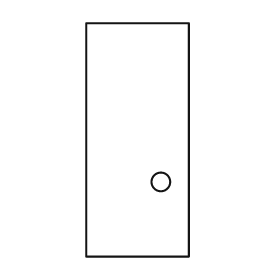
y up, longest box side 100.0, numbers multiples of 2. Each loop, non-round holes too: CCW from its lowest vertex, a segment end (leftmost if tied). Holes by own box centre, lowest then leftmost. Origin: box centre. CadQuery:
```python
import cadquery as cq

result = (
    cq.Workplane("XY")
    .moveTo(-22.0, -50.0)
    .lineTo(22.0, -50.0)
    .lineTo(22.0, 50.0)
    .lineTo(-22.0, 50.0)
    .close()
    .moveTo(10.0, -18.0)
    .circle(4.0)
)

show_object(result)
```